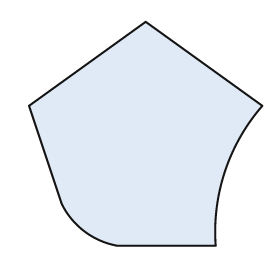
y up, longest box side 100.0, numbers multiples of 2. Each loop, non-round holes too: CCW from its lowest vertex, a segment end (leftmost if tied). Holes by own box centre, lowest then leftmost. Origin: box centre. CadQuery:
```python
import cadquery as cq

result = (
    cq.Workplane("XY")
    .moveTo(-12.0, -48.0)
    .lineTo(30.0, -48.0)
    .threePointArc((34.0, -16.0), (50.0, 12.0))
    .lineTo(0.0, 48.0)
    .lineTo(-50.0, 12.0)
    .lineTo(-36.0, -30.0)
    .threePointArc((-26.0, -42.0), (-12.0, -48.0))
    .close()
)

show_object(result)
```